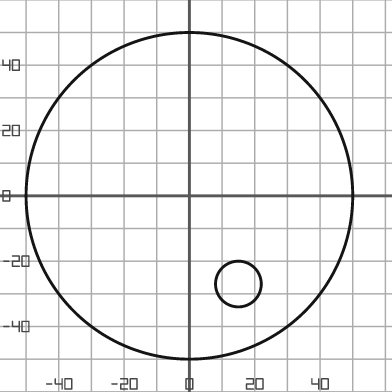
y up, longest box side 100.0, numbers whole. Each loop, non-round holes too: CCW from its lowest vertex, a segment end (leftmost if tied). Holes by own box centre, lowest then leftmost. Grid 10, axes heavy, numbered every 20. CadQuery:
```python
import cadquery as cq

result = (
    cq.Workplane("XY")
    .moveTo(0.0, 0.0)
    .circle(50.0)
    .moveTo(15.0, -27.0)
    .circle(7.0)
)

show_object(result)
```